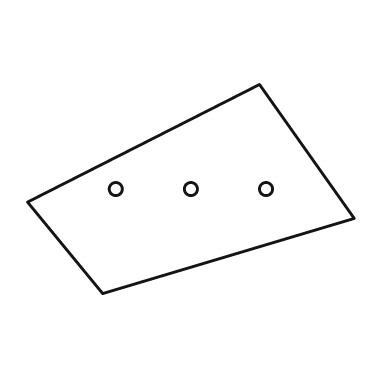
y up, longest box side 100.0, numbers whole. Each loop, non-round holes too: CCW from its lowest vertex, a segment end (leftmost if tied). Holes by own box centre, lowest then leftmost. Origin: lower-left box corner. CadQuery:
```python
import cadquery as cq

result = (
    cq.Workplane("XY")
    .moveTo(23.0, 0.0)
    .lineTo(100.0, 23.0)
    .lineTo(71.0, 64.0)
    .lineTo(0.0, 28.0)
    .close()
    .moveTo(27.0, 32.0)
    .circle(2.0)
    .moveTo(50.0, 32.0)
    .circle(2.0)
    .moveTo(73.0, 32.0)
    .circle(2.0)
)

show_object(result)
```